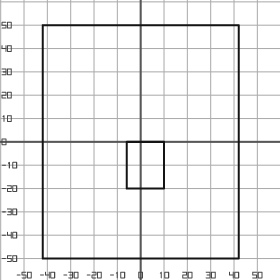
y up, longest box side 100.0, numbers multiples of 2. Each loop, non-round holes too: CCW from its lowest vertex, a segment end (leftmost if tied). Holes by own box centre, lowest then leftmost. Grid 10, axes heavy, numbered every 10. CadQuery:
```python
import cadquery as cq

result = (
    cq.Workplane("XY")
    .moveTo(-42.0, -50.0)
    .lineTo(42.0, -50.0)
    .lineTo(42.0, 50.0)
    .lineTo(-42.0, 50.0)
    .close()
    .moveTo(-6.0, -20.0)
    .lineTo(10.0, -20.0)
    .lineTo(10.0, 0.0)
    .lineTo(-6.0, 0.0)
    .close()
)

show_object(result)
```